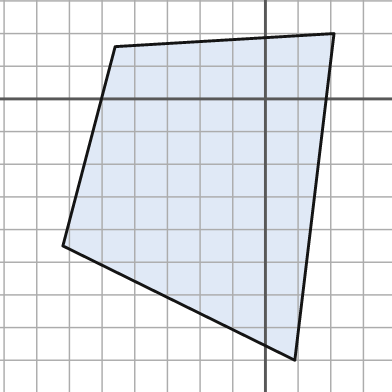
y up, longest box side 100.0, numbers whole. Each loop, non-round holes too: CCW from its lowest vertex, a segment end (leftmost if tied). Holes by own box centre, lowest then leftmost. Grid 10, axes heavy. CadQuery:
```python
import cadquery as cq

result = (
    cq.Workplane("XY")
    .moveTo(9.0, -80.0)
    .lineTo(21.0, 20.0)
    .lineTo(-46.0, 16.0)
    .lineTo(-62.0, -45.0)
    .close()
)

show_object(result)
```